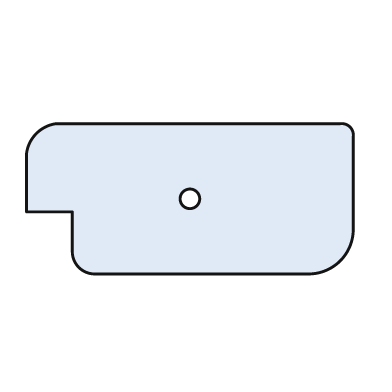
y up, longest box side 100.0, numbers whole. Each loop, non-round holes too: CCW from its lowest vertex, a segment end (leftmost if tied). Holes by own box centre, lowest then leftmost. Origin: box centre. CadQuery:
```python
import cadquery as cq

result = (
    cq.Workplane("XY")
    .moveTo(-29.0, -23.0)
    .lineTo(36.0, -23.0)
    .threePointArc((46.0, -19.0), (50.0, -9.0))
    .lineTo(50.0, 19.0)
    .threePointArc((49.0, 22.0), (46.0, 23.0))
    .lineTo(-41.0, 23.0)
    .threePointArc((-47.0, 20.0), (-50.0, 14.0))
    .lineTo(-50.0, -4.0)
    .lineTo(-36.0, -4.0)
    .lineTo(-36.0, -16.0)
    .threePointArc((-34.0, -21.0), (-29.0, -23.0))
    .close()
    .moveTo(0.0, 0.0)
    .circle(3.0)
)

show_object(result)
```